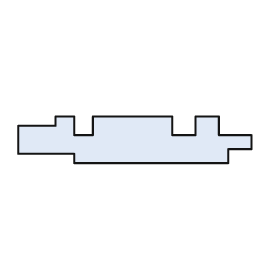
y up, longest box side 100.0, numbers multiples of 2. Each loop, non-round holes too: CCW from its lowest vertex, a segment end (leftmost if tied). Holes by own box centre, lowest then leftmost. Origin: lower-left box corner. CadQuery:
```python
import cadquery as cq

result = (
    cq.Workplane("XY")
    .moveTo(24.0, 0.0)
    .lineTo(90.0, 0.0)
    .lineTo(90.0, 6.0)
    .lineTo(100.0, 6.0)
    .lineTo(100.0, 12.0)
    .lineTo(86.0, 12.0)
    .lineTo(86.0, 20.0)
    .lineTo(76.0, 20.0)
    .lineTo(76.0, 12.0)
    .lineTo(66.0, 12.0)
    .lineTo(66.0, 20.0)
    .lineTo(32.0, 20.0)
    .lineTo(32.0, 12.0)
    .lineTo(24.0, 12.0)
    .lineTo(24.0, 20.0)
    .lineTo(16.0, 20.0)
    .lineTo(16.0, 16.0)
    .lineTo(0.0, 16.0)
    .lineTo(0.0, 4.0)
    .lineTo(24.0, 4.0)
    .close()
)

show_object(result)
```